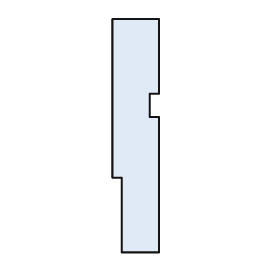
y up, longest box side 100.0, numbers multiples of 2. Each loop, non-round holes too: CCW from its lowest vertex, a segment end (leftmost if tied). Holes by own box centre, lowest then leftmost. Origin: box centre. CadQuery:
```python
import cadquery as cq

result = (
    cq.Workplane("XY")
    .moveTo(-6.0, -50.0)
    .lineTo(10.0, -50.0)
    .lineTo(10.0, 8.0)
    .lineTo(6.0, 8.0)
    .lineTo(6.0, 18.0)
    .lineTo(10.0, 18.0)
    .lineTo(10.0, 50.0)
    .lineTo(-10.0, 50.0)
    .lineTo(-10.0, -18.0)
    .lineTo(-6.0, -18.0)
    .close()
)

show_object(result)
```